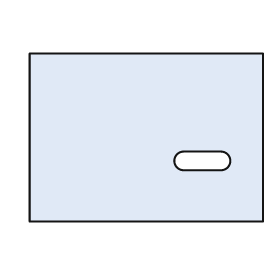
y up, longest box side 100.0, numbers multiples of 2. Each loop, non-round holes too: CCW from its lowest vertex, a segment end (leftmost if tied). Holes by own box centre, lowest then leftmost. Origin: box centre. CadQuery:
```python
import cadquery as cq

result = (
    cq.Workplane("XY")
    .moveTo(-50.0, -36.0)
    .lineTo(50.0, -36.0)
    .lineTo(50.0, 36.0)
    .lineTo(-50.0, 36.0)
    .close()
    .moveTo(16.0, -14.0)
    .lineTo(32.0, -14.0)
    .threePointArc((36.0, -10.0), (32.0, -6.0))
    .lineTo(16.0, -6.0)
    .threePointArc((12.0, -10.0), (16.0, -14.0))
    .close()
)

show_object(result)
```